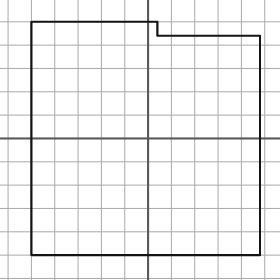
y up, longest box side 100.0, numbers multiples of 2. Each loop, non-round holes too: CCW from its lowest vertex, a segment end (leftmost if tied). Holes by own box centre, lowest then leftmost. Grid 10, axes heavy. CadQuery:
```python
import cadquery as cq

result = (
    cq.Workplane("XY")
    .moveTo(-50.0, -50.0)
    .lineTo(48.0, -50.0)
    .lineTo(48.0, 44.0)
    .lineTo(4.0, 44.0)
    .lineTo(4.0, 50.0)
    .lineTo(-50.0, 50.0)
    .close()
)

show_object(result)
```